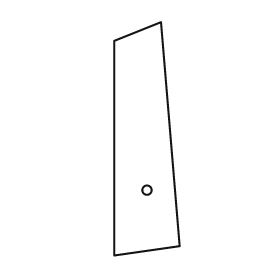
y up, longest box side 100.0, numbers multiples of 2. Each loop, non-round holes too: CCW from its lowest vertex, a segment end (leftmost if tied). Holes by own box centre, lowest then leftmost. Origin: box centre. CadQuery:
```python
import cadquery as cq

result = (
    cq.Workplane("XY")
    .moveTo(-14.0, -50.0)
    .lineTo(14.0, -46.0)
    .lineTo(6.0, 50.0)
    .lineTo(-14.0, 42.0)
    .close()
    .moveTo(0.0, -22.0)
    .circle(2.0)
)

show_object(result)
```